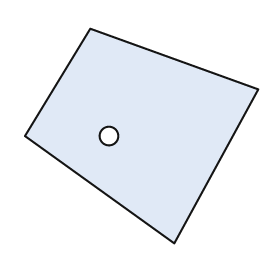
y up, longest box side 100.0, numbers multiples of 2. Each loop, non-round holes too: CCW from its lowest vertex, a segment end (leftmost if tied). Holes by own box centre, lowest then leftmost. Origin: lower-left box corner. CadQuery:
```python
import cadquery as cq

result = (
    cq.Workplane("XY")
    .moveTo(64.0, 0.0)
    .lineTo(100.0, 66.0)
    .lineTo(28.0, 92.0)
    .lineTo(0.0, 46.0)
    .close()
    .moveTo(36.0, 46.0)
    .circle(4.0)
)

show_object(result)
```